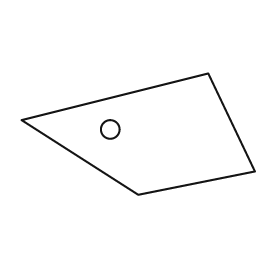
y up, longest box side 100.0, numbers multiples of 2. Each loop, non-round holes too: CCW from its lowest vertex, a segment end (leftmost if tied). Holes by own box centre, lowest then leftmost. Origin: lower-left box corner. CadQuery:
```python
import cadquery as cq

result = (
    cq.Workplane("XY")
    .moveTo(50.0, 0.0)
    .lineTo(100.0, 10.0)
    .lineTo(80.0, 52.0)
    .lineTo(0.0, 32.0)
    .close()
    .moveTo(38.0, 28.0)
    .circle(4.0)
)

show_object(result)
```